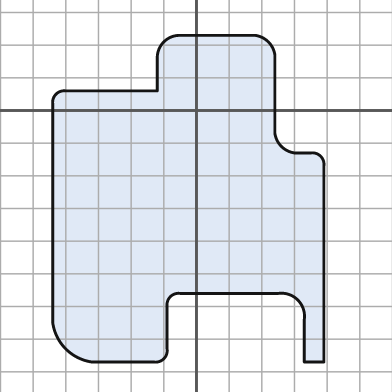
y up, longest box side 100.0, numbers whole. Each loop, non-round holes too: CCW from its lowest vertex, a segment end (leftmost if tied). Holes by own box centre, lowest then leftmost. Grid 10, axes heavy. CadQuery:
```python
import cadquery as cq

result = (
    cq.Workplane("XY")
    .moveTo(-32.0, -77.0)
    .lineTo(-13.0, -77.0)
    .threePointArc((-10.0, -76.0), (-9.0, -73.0))
    .lineTo(-9.0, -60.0)
    .threePointArc((-8.0, -57.0), (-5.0, -56.0))
    .lineTo(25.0, -56.0)
    .threePointArc((31.0, -58.0), (33.0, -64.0))
    .lineTo(33.0, -77.0)
    .lineTo(39.0, -77.0)
    .lineTo(39.0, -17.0)
    .threePointArc((38.0, -14.0), (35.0, -13.0))
    .lineTo(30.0, -13.0)
    .threePointArc((26.0, -11.0), (24.0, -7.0))
    .lineTo(24.0, 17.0)
    .threePointArc((22.0, 21.0), (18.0, 23.0))
    .lineTo(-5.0, 23.0)
    .threePointArc((-10.0, 21.0), (-12.0, 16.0))
    .lineTo(-12.0, 6.0)
    .lineTo(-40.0, 6.0)
    .threePointArc((-43.0, 5.0), (-44.0, 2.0))
    .lineTo(-44.0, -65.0)
    .threePointArc((-40.0, -73.0), (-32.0, -77.0))
    .close()
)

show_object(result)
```